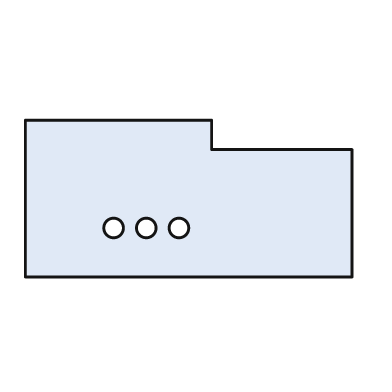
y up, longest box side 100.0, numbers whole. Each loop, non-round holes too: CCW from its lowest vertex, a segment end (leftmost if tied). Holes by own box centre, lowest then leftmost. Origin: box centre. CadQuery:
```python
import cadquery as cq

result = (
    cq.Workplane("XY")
    .moveTo(-50.0, -24.0)
    .lineTo(50.0, -24.0)
    .lineTo(50.0, 15.0)
    .lineTo(7.0, 15.0)
    .lineTo(7.0, 24.0)
    .lineTo(-50.0, 24.0)
    .close()
    .moveTo(-23.0, -9.0)
    .circle(3.0)
    .moveTo(-13.0, -9.0)
    .circle(3.0)
    .moveTo(-3.0, -9.0)
    .circle(3.0)
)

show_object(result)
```